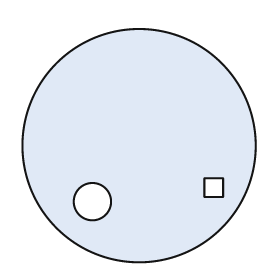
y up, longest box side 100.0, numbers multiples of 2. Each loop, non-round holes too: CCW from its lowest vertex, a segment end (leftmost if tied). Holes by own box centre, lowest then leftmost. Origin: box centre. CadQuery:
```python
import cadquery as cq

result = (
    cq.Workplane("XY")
    .moveTo(0.0, 0.0)
    .circle(50.0)
    .moveTo(-20.0, -24.0)
    .circle(8.0)
    .moveTo(28.0, -22.0)
    .lineTo(36.0, -22.0)
    .lineTo(36.0, -14.0)
    .lineTo(28.0, -14.0)
    .close()
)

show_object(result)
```